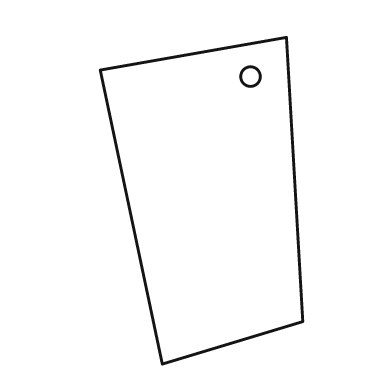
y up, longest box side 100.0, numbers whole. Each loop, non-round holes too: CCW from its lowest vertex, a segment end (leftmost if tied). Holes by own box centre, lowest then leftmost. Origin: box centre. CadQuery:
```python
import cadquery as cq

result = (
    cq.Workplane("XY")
    .moveTo(-12.0, -50.0)
    .lineTo(31.0, -37.0)
    .lineTo(26.0, 50.0)
    .lineTo(-31.0, 40.0)
    .close()
    .moveTo(15.0, 38.0)
    .circle(3.0)
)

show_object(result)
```